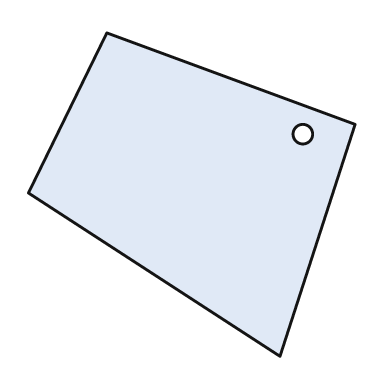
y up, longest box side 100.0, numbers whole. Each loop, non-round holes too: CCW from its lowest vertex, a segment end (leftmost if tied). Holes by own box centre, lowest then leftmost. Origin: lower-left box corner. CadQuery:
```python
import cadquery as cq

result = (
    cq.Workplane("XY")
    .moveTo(77.0, 0.0)
    .lineTo(100.0, 71.0)
    .lineTo(24.0, 99.0)
    .lineTo(0.0, 50.0)
    .close()
    .moveTo(84.0, 68.0)
    .circle(3.0)
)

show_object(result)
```